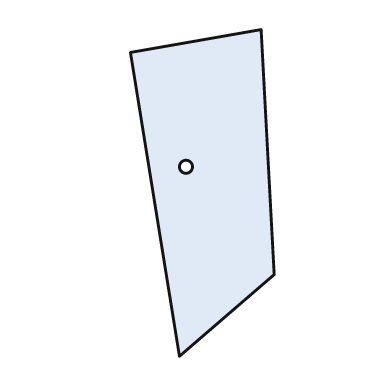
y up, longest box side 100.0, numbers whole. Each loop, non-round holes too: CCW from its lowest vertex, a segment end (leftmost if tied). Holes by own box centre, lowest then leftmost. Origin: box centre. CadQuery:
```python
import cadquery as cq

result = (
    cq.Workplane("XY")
    .moveTo(-7.0, -50.0)
    .lineTo(22.0, -25.0)
    .lineTo(18.0, 50.0)
    .lineTo(-22.0, 43.0)
    .close()
    .moveTo(-5.0, 8.0)
    .circle(2.0)
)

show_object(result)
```